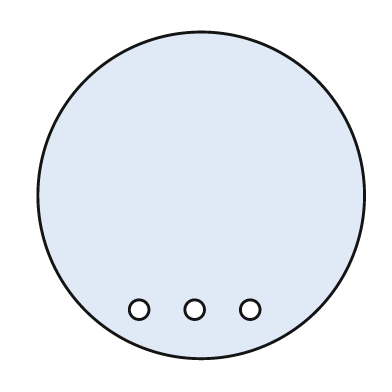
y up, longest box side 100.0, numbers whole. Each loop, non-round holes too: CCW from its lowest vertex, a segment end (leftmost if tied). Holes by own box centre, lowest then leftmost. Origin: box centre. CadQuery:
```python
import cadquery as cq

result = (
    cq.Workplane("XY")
    .moveTo(0.0, 0.0)
    .circle(50.0)
    .moveTo(-19.0, -35.0)
    .circle(3.0)
    .moveTo(-2.0, -35.0)
    .circle(3.0)
    .moveTo(15.0, -35.0)
    .circle(3.0)
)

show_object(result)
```